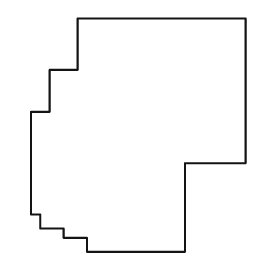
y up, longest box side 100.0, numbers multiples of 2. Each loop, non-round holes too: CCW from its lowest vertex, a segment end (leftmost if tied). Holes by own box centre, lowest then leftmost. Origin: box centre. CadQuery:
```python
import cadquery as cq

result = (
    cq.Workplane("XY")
    .moveTo(-22.0, -50.0)
    .lineTo(20.0, -50.0)
    .lineTo(20.0, -12.0)
    .lineTo(46.0, -12.0)
    .lineTo(46.0, 50.0)
    .lineTo(-26.0, 50.0)
    .lineTo(-26.0, 28.0)
    .lineTo(-38.0, 28.0)
    .lineTo(-38.0, 10.0)
    .lineTo(-46.0, 10.0)
    .lineTo(-46.0, -34.0)
    .lineTo(-42.0, -34.0)
    .lineTo(-42.0, -40.0)
    .lineTo(-32.0, -40.0)
    .lineTo(-32.0, -44.0)
    .lineTo(-22.0, -44.0)
    .close()
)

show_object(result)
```